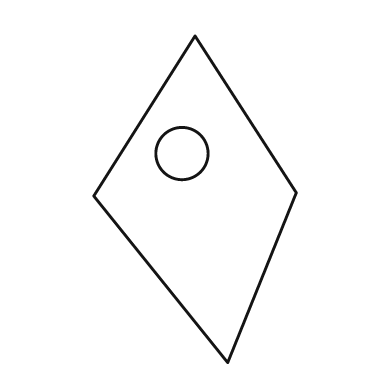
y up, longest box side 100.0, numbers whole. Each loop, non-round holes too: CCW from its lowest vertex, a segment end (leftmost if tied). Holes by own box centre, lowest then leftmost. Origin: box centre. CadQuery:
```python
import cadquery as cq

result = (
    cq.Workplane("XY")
    .moveTo(10.0, -50.0)
    .lineTo(31.0, 2.0)
    .lineTo(0.0, 50.0)
    .lineTo(-31.0, 1.0)
    .close()
    .moveTo(-4.0, 14.0)
    .circle(8.0)
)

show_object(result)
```